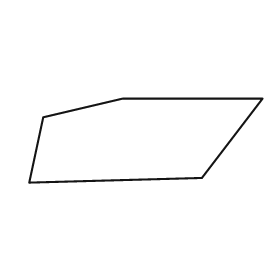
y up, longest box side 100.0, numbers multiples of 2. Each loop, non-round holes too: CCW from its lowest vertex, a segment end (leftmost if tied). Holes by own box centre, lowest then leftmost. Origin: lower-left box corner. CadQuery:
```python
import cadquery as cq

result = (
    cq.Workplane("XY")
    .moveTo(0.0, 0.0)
    .lineTo(74.0, 2.0)
    .lineTo(100.0, 36.0)
    .lineTo(40.0, 36.0)
    .lineTo(6.0, 28.0)
    .close()
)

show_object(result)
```